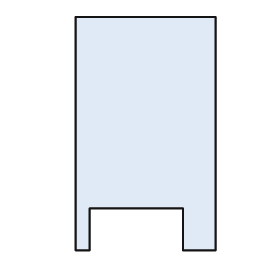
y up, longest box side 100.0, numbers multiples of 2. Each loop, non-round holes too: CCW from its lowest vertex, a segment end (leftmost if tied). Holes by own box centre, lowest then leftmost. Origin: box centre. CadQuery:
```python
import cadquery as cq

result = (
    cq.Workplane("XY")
    .moveTo(-30.0, -50.0)
    .lineTo(-24.0, -50.0)
    .lineTo(-24.0, -32.0)
    .lineTo(16.0, -32.0)
    .lineTo(16.0, -50.0)
    .lineTo(30.0, -50.0)
    .lineTo(30.0, 50.0)
    .lineTo(-30.0, 50.0)
    .close()
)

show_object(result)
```